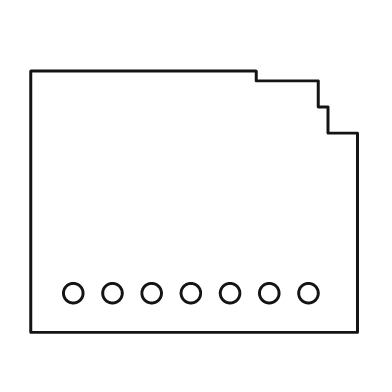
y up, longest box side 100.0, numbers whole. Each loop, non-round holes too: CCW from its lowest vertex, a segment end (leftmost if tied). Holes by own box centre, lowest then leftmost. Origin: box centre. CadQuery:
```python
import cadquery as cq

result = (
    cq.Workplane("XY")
    .moveTo(-50.0, -40.0)
    .lineTo(50.0, -40.0)
    .lineTo(50.0, 21.0)
    .lineTo(41.0, 21.0)
    .lineTo(41.0, 29.0)
    .lineTo(38.0, 29.0)
    .lineTo(38.0, 37.0)
    .lineTo(19.0, 37.0)
    .lineTo(19.0, 40.0)
    .lineTo(-50.0, 40.0)
    .close()
    .moveTo(-37.0, -28.0)
    .circle(3.0)
    .moveTo(-25.0, -28.0)
    .circle(3.0)
    .moveTo(-13.0, -28.0)
    .circle(3.0)
    .moveTo(-1.0, -28.0)
    .circle(3.0)
    .moveTo(11.0, -28.0)
    .circle(3.0)
    .moveTo(23.0, -28.0)
    .circle(3.0)
    .moveTo(35.0, -28.0)
    .circle(3.0)
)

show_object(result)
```